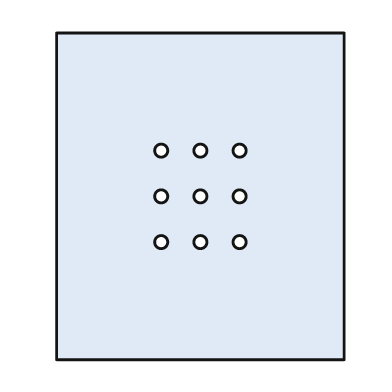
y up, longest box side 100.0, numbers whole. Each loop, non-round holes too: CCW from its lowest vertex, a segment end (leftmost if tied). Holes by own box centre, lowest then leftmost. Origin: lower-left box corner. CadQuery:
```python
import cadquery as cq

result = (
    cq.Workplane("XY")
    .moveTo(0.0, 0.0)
    .lineTo(88.0, 0.0)
    .lineTo(88.0, 100.0)
    .lineTo(0.0, 100.0)
    .close()
    .moveTo(32.0, 36.0)
    .circle(2.0)
    .moveTo(44.0, 36.0)
    .circle(2.0)
    .moveTo(56.0, 36.0)
    .circle(2.0)
    .moveTo(32.0, 50.0)
    .circle(2.0)
    .moveTo(44.0, 50.0)
    .circle(2.0)
    .moveTo(56.0, 50.0)
    .circle(2.0)
    .moveTo(32.0, 64.0)
    .circle(2.0)
    .moveTo(44.0, 64.0)
    .circle(2.0)
    .moveTo(56.0, 64.0)
    .circle(2.0)
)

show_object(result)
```